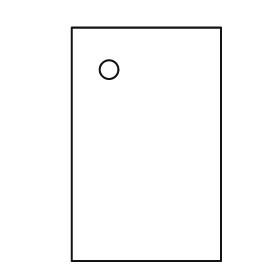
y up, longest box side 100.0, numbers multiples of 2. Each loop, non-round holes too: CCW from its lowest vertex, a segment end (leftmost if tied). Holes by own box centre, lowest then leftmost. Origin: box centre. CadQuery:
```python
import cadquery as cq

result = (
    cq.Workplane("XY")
    .moveTo(-32.0, -50.0)
    .lineTo(32.0, -50.0)
    .lineTo(32.0, 50.0)
    .lineTo(-32.0, 50.0)
    .close()
    .moveTo(-16.0, 32.0)
    .circle(4.0)
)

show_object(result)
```